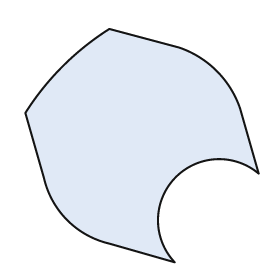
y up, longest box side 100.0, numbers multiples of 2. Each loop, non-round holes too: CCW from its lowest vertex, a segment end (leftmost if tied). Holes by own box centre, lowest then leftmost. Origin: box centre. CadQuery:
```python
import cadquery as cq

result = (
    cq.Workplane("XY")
    .moveTo(14.0, -50.0)
    .threePointArc((14.0, -14.0), (50.0, -12.0))
    .lineTo(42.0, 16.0)
    .threePointArc((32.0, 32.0), (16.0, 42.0))
    .lineTo(-14.0, 50.0)
    .threePointArc((-34.0, 34.0), (-50.0, 14.0))
    .lineTo(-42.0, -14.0)
    .threePointArc((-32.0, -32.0), (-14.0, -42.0))
    .close()
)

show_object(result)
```